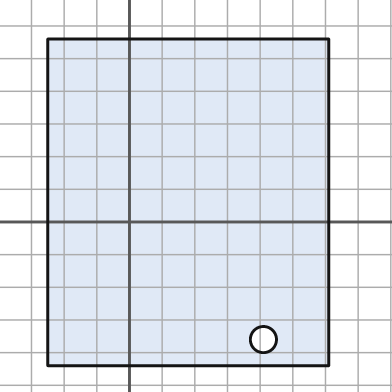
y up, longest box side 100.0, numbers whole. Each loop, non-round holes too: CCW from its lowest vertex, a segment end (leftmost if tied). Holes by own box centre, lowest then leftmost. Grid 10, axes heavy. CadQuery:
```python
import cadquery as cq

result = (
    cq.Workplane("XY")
    .moveTo(-25.0, -44.0)
    .lineTo(61.0, -44.0)
    .lineTo(61.0, 56.0)
    .lineTo(-25.0, 56.0)
    .close()
    .moveTo(41.0, -36.0)
    .circle(4.0)
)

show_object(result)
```